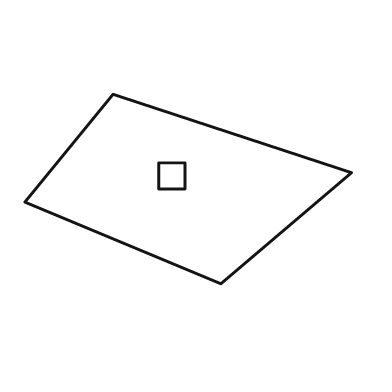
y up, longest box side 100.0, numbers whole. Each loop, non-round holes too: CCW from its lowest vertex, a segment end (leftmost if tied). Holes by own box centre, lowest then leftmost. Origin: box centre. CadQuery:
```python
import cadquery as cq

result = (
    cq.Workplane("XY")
    .moveTo(10.0, -29.0)
    .lineTo(50.0, 5.0)
    .lineTo(-23.0, 29.0)
    .lineTo(-50.0, -4.0)
    .close()
    .moveTo(-9.0, 0.0)
    .lineTo(-1.0, 0.0)
    .lineTo(-1.0, 8.0)
    .lineTo(-9.0, 8.0)
    .close()
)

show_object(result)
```